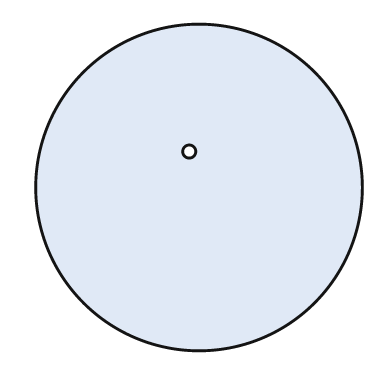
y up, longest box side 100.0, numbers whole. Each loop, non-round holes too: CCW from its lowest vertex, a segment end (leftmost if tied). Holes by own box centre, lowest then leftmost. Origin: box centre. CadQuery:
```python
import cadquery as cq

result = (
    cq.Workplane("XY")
    .moveTo(0.0, 0.0)
    .circle(50.0)
    .moveTo(-3.0, 11.0)
    .circle(2.0)
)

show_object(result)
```